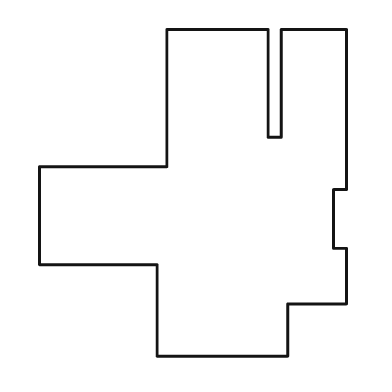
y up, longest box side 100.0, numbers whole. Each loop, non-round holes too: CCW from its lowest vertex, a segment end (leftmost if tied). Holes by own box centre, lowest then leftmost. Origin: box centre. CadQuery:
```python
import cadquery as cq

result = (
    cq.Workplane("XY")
    .moveTo(-11.0, -50.0)
    .lineTo(29.0, -50.0)
    .lineTo(29.0, -34.0)
    .lineTo(47.0, -34.0)
    .lineTo(47.0, -17.0)
    .lineTo(43.0, -17.0)
    .lineTo(43.0, 1.0)
    .lineTo(47.0, 1.0)
    .lineTo(47.0, 50.0)
    .lineTo(27.0, 50.0)
    .lineTo(27.0, 17.0)
    .lineTo(23.0, 17.0)
    .lineTo(23.0, 50.0)
    .lineTo(-8.0, 50.0)
    .lineTo(-8.0, 8.0)
    .lineTo(-47.0, 8.0)
    .lineTo(-47.0, -22.0)
    .lineTo(-11.0, -22.0)
    .close()
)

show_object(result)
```